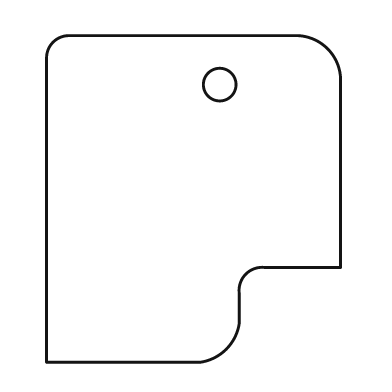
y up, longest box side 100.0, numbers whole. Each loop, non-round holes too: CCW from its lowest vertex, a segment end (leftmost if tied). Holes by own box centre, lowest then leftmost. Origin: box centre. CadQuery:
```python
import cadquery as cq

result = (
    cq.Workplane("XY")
    .moveTo(-45.0, -50.0)
    .lineTo(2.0, -50.0)
    .threePointArc((10.0, -46.0), (14.0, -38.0))
    .lineTo(14.0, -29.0)
    .threePointArc((16.0, -23.0), (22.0, -21.0))
    .lineTo(45.0, -21.0)
    .lineTo(45.0, 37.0)
    .threePointArc((41.0, 46.0), (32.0, 50.0))
    .lineTo(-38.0, 50.0)
    .threePointArc((-43.0, 48.0), (-45.0, 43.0))
    .close()
    .moveTo(8.0, 35.0)
    .circle(5.0)
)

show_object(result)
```